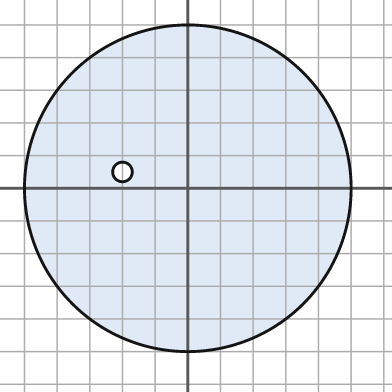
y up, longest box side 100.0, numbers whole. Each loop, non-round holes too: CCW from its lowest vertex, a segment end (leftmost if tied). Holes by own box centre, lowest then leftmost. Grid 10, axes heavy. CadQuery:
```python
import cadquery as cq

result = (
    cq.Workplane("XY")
    .moveTo(0.0, 0.0)
    .circle(50.0)
    .moveTo(-20.0, 5.0)
    .circle(3.0)
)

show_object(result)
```